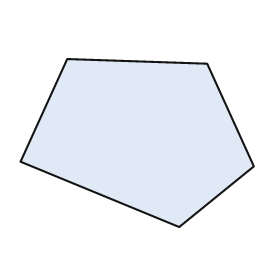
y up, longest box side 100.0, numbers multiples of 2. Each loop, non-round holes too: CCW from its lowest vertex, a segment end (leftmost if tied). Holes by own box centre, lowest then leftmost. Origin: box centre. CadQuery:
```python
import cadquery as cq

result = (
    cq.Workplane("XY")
    .moveTo(18.0, -36.0)
    .lineTo(50.0, -10.0)
    .lineTo(30.0, 34.0)
    .lineTo(-30.0, 36.0)
    .lineTo(-50.0, -8.0)
    .close()
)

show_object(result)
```